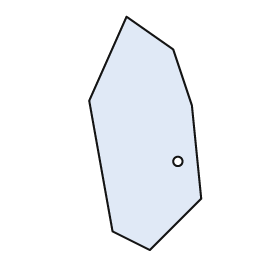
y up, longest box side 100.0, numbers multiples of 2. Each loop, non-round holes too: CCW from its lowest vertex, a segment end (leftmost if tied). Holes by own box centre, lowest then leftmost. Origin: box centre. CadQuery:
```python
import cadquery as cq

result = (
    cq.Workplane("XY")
    .moveTo(2.0, -50.0)
    .lineTo(24.0, -28.0)
    .lineTo(20.0, 12.0)
    .lineTo(12.0, 36.0)
    .lineTo(-8.0, 50.0)
    .lineTo(-24.0, 14.0)
    .lineTo(-14.0, -42.0)
    .close()
    .moveTo(14.0, -12.0)
    .circle(2.0)
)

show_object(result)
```